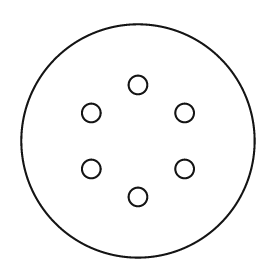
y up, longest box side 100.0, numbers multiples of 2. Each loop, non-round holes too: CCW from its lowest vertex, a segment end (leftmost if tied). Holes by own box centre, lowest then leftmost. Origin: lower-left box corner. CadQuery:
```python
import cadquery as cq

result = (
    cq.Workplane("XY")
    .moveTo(50.0, 50.0)
    .circle(50.0)
    .moveTo(50.0, 26.0)
    .circle(4.0)
    .moveTo(30.0, 38.0)
    .circle(4.0)
    .moveTo(70.0, 38.0)
    .circle(4.0)
    .moveTo(30.0, 62.0)
    .circle(4.0)
    .moveTo(70.0, 62.0)
    .circle(4.0)
    .moveTo(50.0, 74.0)
    .circle(4.0)
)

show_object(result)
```